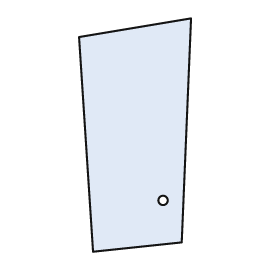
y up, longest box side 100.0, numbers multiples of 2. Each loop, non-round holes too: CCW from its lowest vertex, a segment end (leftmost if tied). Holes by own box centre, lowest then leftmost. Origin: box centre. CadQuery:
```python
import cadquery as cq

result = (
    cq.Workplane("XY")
    .moveTo(-18.0, -50.0)
    .lineTo(20.0, -46.0)
    .lineTo(24.0, 50.0)
    .lineTo(-24.0, 42.0)
    .close()
    .moveTo(12.0, -28.0)
    .circle(2.0)
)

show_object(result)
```